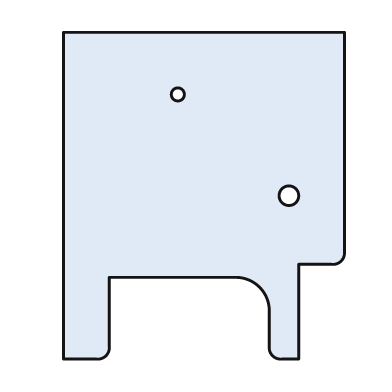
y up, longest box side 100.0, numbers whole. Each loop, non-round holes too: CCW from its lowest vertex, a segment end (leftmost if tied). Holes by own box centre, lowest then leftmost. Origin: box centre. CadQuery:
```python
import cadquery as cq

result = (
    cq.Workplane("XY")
    .moveTo(-43.0, -50.0)
    .lineTo(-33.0, -50.0)
    .threePointArc((-30.0, -49.0), (-29.0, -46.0))
    .lineTo(-29.0, -25.0)
    .lineTo(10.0, -25.0)
    .threePointArc((17.0, -28.0), (20.0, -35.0))
    .lineTo(20.0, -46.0)
    .threePointArc((21.0, -49.0), (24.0, -50.0))
    .lineTo(29.0, -50.0)
    .lineTo(29.0, -21.0)
    .lineTo(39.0, -21.0)
    .threePointArc((42.0, -20.0), (43.0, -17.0))
    .lineTo(43.0, 50.0)
    .lineTo(-43.0, 50.0)
    .close()
    .moveTo(26.0, 0.0)
    .circle(3.0)
    .moveTo(-8.0, 31.0)
    .circle(2.0)
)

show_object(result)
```